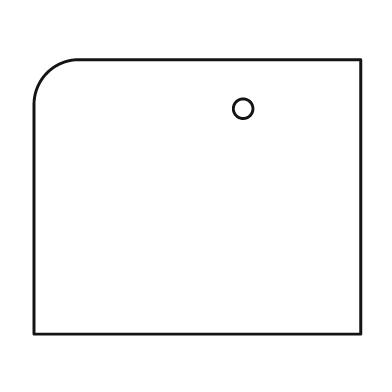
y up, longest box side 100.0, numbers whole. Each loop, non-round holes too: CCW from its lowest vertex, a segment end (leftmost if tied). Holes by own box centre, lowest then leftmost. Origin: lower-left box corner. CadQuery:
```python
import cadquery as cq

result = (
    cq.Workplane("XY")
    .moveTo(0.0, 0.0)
    .lineTo(100.0, 0.0)
    .lineTo(100.0, 84.0)
    .lineTo(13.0, 84.0)
    .threePointArc((4.0, 80.0), (0.0, 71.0))
    .close()
    .moveTo(64.0, 69.0)
    .circle(3.0)
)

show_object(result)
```